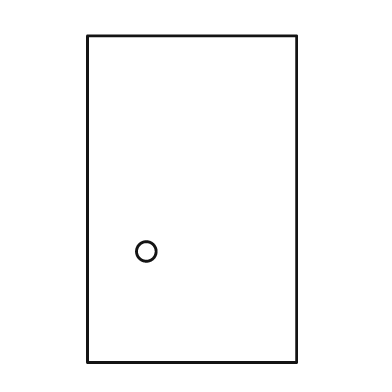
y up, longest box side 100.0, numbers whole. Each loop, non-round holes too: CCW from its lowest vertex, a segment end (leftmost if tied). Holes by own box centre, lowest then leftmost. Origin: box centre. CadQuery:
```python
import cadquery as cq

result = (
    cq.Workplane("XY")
    .moveTo(-32.0, -50.0)
    .lineTo(32.0, -50.0)
    .lineTo(32.0, 50.0)
    .lineTo(-32.0, 50.0)
    .close()
    .moveTo(-14.0, -16.0)
    .circle(3.0)
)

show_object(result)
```